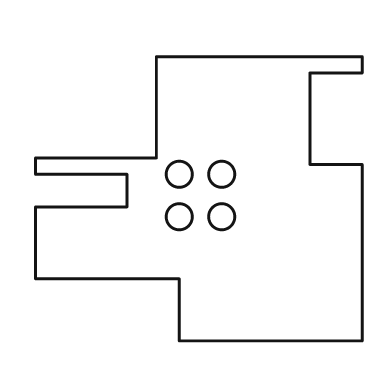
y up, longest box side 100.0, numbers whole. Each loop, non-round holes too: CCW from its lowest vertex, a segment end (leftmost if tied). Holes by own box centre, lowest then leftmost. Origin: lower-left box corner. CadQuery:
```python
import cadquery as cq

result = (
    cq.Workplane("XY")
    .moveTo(44.0, 0.0)
    .lineTo(100.0, 0.0)
    .lineTo(100.0, 54.0)
    .lineTo(84.0, 54.0)
    .lineTo(84.0, 82.0)
    .lineTo(100.0, 82.0)
    .lineTo(100.0, 87.0)
    .lineTo(37.0, 87.0)
    .lineTo(37.0, 56.0)
    .lineTo(0.0, 56.0)
    .lineTo(0.0, 51.0)
    .lineTo(28.0, 51.0)
    .lineTo(28.0, 41.0)
    .lineTo(0.0, 41.0)
    .lineTo(0.0, 19.0)
    .lineTo(44.0, 19.0)
    .close()
    .moveTo(44.0, 38.0)
    .circle(4.0)
    .moveTo(57.0, 38.0)
    .circle(4.0)
    .moveTo(44.0, 51.0)
    .circle(4.0)
    .moveTo(57.0, 51.0)
    .circle(4.0)
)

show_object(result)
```